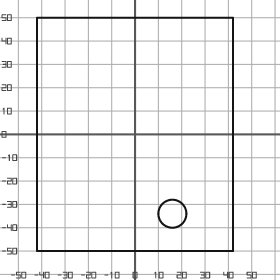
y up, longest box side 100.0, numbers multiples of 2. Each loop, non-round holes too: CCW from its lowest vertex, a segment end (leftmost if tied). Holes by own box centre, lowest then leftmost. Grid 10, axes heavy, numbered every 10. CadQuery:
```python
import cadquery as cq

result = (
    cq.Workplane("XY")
    .moveTo(-42.0, -50.0)
    .lineTo(42.0, -50.0)
    .lineTo(42.0, 50.0)
    .lineTo(-42.0, 50.0)
    .close()
    .moveTo(16.0, -34.0)
    .circle(6.0)
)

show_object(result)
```